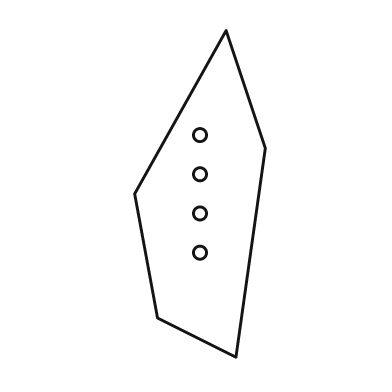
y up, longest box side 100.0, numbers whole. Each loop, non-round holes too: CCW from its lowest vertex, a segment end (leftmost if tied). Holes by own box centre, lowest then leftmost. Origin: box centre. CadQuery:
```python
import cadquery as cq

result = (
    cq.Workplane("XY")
    .moveTo(11.0, -50.0)
    .lineTo(20.0, 14.0)
    .lineTo(8.0, 50.0)
    .lineTo(-20.0, 0.0)
    .lineTo(-13.0, -38.0)
    .close()
    .moveTo(0.0, -18.0)
    .circle(2.0)
    .moveTo(0.0, -6.0)
    .circle(2.0)
    .moveTo(0.0, 6.0)
    .circle(2.0)
    .moveTo(0.0, 18.0)
    .circle(2.0)
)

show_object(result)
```